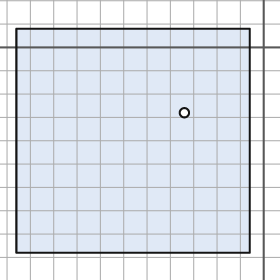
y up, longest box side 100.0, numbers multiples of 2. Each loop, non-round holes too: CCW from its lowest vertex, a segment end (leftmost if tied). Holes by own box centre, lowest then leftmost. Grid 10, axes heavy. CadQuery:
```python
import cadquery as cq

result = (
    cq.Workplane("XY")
    .moveTo(-106.0, -88.0)
    .lineTo(-6.0, -88.0)
    .lineTo(-6.0, 8.0)
    .lineTo(-106.0, 8.0)
    .close()
    .moveTo(-34.0, -28.0)
    .circle(2.0)
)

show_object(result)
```